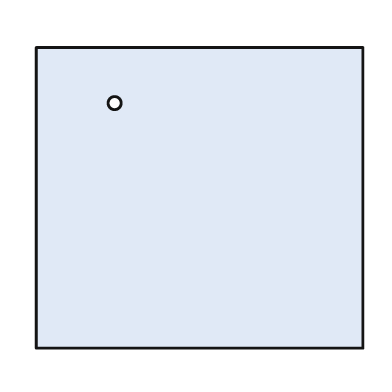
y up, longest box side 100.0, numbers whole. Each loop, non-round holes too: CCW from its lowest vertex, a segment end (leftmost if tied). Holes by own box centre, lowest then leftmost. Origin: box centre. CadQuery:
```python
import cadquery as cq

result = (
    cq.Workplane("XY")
    .moveTo(-50.0, -46.0)
    .lineTo(50.0, -46.0)
    .lineTo(50.0, 46.0)
    .lineTo(-50.0, 46.0)
    .close()
    .moveTo(-26.0, 29.0)
    .circle(2.0)
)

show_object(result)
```